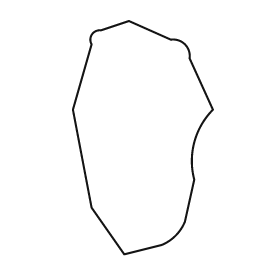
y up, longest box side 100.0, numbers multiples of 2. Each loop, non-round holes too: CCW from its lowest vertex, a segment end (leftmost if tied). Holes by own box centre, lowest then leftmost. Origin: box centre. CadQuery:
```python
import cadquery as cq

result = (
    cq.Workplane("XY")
    .moveTo(-8.0, -50.0)
    .lineTo(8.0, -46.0)
    .threePointArc((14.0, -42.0), (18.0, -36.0))
    .lineTo(22.0, -18.0)
    .threePointArc((22.0, -2.0), (30.0, 12.0))
    .lineTo(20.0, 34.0)
    .threePointArc((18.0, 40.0), (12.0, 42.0))
    .lineTo(-6.0, 50.0)
    .lineTo(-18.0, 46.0)
    .threePointArc((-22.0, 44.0), (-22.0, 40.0))
    .lineTo(-30.0, 12.0)
    .lineTo(-22.0, -30.0)
    .close()
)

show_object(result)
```